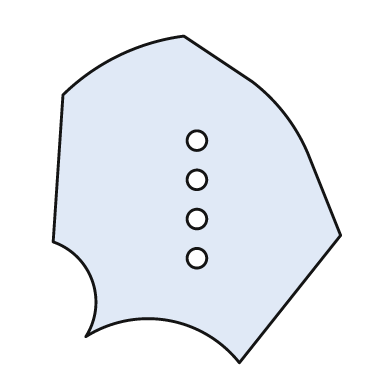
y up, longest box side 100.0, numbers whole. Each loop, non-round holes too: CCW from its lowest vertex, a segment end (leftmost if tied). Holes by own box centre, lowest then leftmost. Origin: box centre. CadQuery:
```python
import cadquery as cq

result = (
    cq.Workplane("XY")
    .moveTo(13.0, -50.0)
    .lineTo(44.0, -11.0)
    .lineTo(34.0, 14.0)
    .threePointArc((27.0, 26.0), (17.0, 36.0))
    .lineTo(-4.0, 50.0)
    .threePointArc((-24.0, 44.0), (-41.0, 32.0))
    .lineTo(-44.0, -13.0)
    .threePointArc((-32.0, -25.0), (-34.0, -42.0))
    .threePointArc((-9.0, -37.0), (13.0, -50.0))
    .close()
    .moveTo(0.0, -18.0)
    .circle(3.0)
    .moveTo(0.0, -6.0)
    .circle(3.0)
    .moveTo(0.0, 6.0)
    .circle(3.0)
    .moveTo(0.0, 18.0)
    .circle(3.0)
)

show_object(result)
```